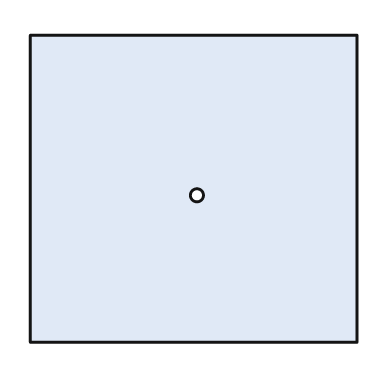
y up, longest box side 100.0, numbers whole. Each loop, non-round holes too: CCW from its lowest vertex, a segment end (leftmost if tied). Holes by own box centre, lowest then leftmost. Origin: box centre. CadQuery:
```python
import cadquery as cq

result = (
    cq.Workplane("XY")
    .moveTo(-50.0, -47.0)
    .lineTo(50.0, -47.0)
    .lineTo(50.0, 47.0)
    .lineTo(-50.0, 47.0)
    .close()
    .moveTo(1.0, -2.0)
    .circle(2.0)
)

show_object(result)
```